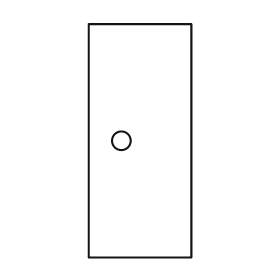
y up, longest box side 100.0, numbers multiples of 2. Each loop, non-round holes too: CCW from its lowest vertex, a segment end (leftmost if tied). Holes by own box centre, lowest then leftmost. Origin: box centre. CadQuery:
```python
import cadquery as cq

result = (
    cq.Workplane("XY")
    .moveTo(-22.0, -50.0)
    .lineTo(22.0, -50.0)
    .lineTo(22.0, 50.0)
    .lineTo(-22.0, 50.0)
    .close()
    .moveTo(-8.0, 0.0)
    .circle(4.0)
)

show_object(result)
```